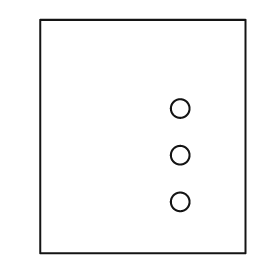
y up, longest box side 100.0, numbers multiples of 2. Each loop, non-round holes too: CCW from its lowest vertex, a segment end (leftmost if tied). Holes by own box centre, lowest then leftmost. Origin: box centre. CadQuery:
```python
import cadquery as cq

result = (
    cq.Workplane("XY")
    .moveTo(-44.0, -50.0)
    .lineTo(44.0, -50.0)
    .lineTo(44.0, 50.0)
    .lineTo(-44.0, 50.0)
    .close()
    .moveTo(16.0, -28.0)
    .circle(4.0)
    .moveTo(16.0, -8.0)
    .circle(4.0)
    .moveTo(16.0, 12.0)
    .circle(4.0)
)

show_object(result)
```